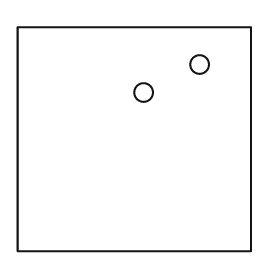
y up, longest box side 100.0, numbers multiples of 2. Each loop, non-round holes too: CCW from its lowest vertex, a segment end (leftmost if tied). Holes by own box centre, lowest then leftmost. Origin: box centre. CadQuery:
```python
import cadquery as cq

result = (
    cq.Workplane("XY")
    .moveTo(-50.0, -48.0)
    .lineTo(50.0, -48.0)
    .lineTo(50.0, 48.0)
    .lineTo(-50.0, 48.0)
    .close()
    .moveTo(4.0, 20.0)
    .circle(4.0)
    .moveTo(28.0, 32.0)
    .circle(4.0)
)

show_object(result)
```